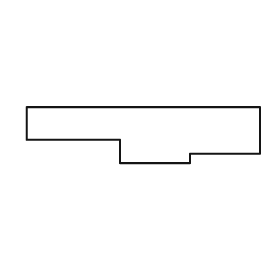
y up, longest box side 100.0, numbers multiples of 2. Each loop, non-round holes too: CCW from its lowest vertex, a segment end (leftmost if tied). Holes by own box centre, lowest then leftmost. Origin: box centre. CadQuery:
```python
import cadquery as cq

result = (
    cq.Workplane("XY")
    .moveTo(-10.0, -12.0)
    .lineTo(20.0, -12.0)
    .lineTo(20.0, -8.0)
    .lineTo(50.0, -8.0)
    .lineTo(50.0, 12.0)
    .lineTo(-50.0, 12.0)
    .lineTo(-50.0, -2.0)
    .lineTo(-10.0, -2.0)
    .close()
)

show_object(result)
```